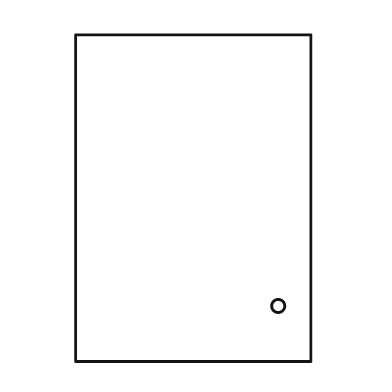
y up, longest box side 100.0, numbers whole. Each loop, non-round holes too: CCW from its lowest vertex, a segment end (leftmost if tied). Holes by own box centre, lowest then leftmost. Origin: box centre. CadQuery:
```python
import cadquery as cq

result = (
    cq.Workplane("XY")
    .moveTo(-36.0, -50.0)
    .lineTo(36.0, -50.0)
    .lineTo(36.0, 50.0)
    .lineTo(-36.0, 50.0)
    .close()
    .moveTo(26.0, -33.0)
    .circle(2.0)
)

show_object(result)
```